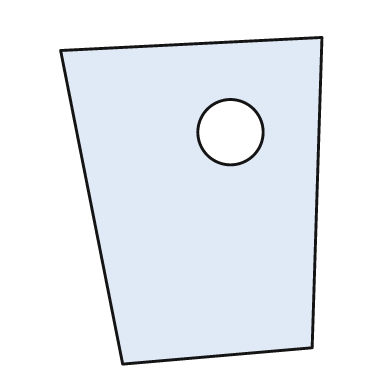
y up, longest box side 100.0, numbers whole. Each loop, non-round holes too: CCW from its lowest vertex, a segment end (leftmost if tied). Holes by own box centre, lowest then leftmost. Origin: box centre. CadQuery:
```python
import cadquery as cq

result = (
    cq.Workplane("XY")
    .moveTo(-21.0, -50.0)
    .lineTo(37.0, -45.0)
    .lineTo(40.0, 50.0)
    .lineTo(-40.0, 46.0)
    .close()
    .moveTo(12.0, 21.0)
    .circle(10.0)
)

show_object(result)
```